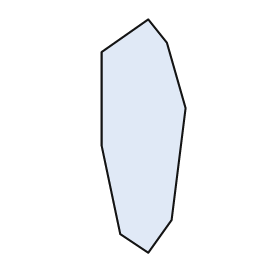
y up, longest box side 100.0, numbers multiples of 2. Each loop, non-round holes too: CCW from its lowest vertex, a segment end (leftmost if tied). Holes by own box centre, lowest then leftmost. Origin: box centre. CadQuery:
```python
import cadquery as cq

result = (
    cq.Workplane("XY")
    .moveTo(2.0, -50.0)
    .lineTo(12.0, -36.0)
    .lineTo(18.0, 12.0)
    .lineTo(10.0, 40.0)
    .lineTo(2.0, 50.0)
    .lineTo(-18.0, 36.0)
    .lineTo(-18.0, -4.0)
    .lineTo(-10.0, -42.0)
    .close()
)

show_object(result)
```